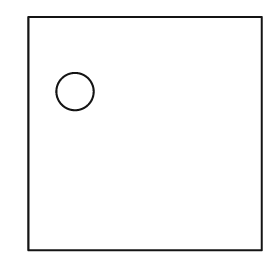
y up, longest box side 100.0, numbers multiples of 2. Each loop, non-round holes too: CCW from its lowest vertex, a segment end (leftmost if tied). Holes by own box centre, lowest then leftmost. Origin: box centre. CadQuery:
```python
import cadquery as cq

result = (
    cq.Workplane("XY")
    .moveTo(-50.0, -50.0)
    .lineTo(50.0, -50.0)
    .lineTo(50.0, 50.0)
    .lineTo(-50.0, 50.0)
    .close()
    .moveTo(-30.0, 18.0)
    .circle(8.0)
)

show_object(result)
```